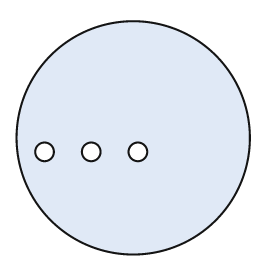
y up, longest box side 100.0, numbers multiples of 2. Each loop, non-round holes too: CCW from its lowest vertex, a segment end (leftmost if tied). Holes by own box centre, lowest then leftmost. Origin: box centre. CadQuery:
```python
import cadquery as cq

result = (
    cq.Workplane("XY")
    .moveTo(0.0, 0.0)
    .circle(50.0)
    .moveTo(-38.0, -6.0)
    .circle(4.0)
    .moveTo(-18.0, -6.0)
    .circle(4.0)
    .moveTo(2.0, -6.0)
    .circle(4.0)
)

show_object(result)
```